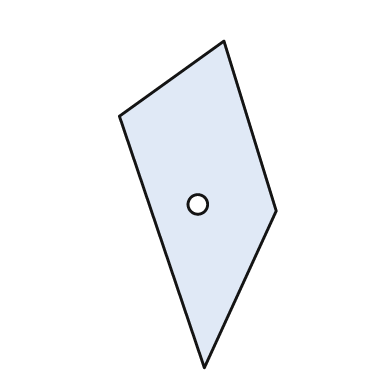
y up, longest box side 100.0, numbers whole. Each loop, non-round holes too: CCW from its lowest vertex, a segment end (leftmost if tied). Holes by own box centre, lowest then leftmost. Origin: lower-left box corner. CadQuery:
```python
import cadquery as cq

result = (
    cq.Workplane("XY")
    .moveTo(26.0, 0.0)
    .lineTo(48.0, 48.0)
    .lineTo(32.0, 100.0)
    .lineTo(0.0, 77.0)
    .close()
    .moveTo(24.0, 50.0)
    .circle(3.0)
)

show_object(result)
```